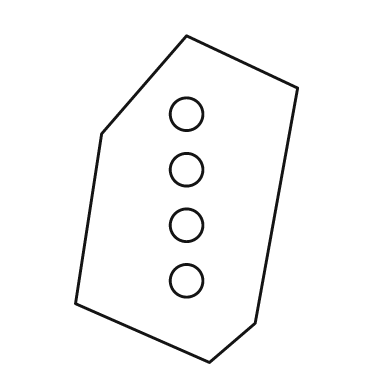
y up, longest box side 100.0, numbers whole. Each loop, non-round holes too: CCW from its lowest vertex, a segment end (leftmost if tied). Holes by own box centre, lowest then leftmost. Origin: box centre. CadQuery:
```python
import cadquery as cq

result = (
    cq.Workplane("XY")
    .moveTo(7.0, -50.0)
    .lineTo(21.0, -38.0)
    .lineTo(34.0, 34.0)
    .lineTo(0.0, 50.0)
    .lineTo(-26.0, 20.0)
    .lineTo(-34.0, -32.0)
    .close()
    .moveTo(0.0, -25.0)
    .circle(5.0)
    .moveTo(0.0, -8.0)
    .circle(5.0)
    .moveTo(0.0, 9.0)
    .circle(5.0)
    .moveTo(0.0, 26.0)
    .circle(5.0)
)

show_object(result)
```